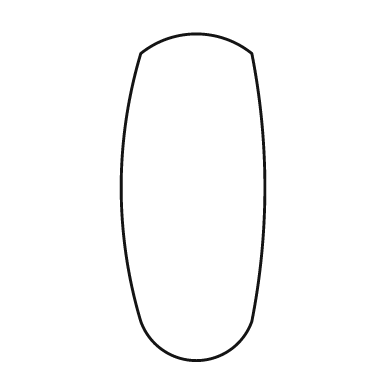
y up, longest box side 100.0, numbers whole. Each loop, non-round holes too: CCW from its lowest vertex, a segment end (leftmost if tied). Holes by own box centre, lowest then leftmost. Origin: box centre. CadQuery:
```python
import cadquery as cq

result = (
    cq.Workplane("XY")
    .moveTo(-16.0, -38.0)
    .threePointArc((1.0, -50.0), (18.0, -38.0))
    .threePointArc((22.0, 3.0), (18.0, 44.0))
    .threePointArc((1.0, 50.0), (-16.0, 44.0))
    .threePointArc((-22.0, 3.0), (-16.0, -38.0))
    .close()
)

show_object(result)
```